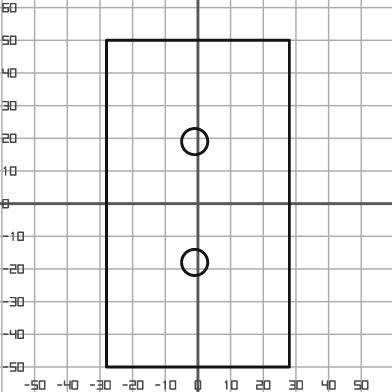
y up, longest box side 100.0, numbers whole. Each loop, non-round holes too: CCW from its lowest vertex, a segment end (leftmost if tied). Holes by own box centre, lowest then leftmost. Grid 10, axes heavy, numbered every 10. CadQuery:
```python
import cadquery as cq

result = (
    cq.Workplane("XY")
    .moveTo(-28.0, -50.0)
    .lineTo(28.0, -50.0)
    .lineTo(28.0, 50.0)
    .lineTo(-28.0, 50.0)
    .close()
    .moveTo(-1.0, -18.0)
    .circle(4.0)
    .moveTo(-1.0, 19.0)
    .circle(4.0)
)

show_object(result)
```